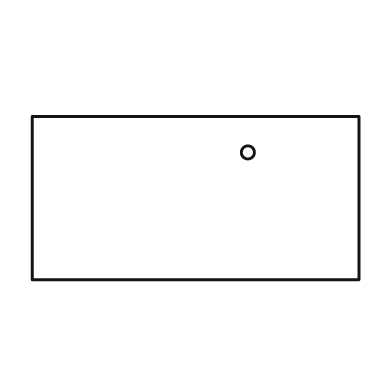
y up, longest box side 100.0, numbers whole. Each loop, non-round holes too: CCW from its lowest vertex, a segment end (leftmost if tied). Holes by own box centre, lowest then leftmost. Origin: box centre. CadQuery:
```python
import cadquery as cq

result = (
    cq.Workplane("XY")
    .moveTo(-50.0, -25.0)
    .lineTo(50.0, -25.0)
    .lineTo(50.0, 25.0)
    .lineTo(-50.0, 25.0)
    .close()
    .moveTo(16.0, 14.0)
    .circle(2.0)
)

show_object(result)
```